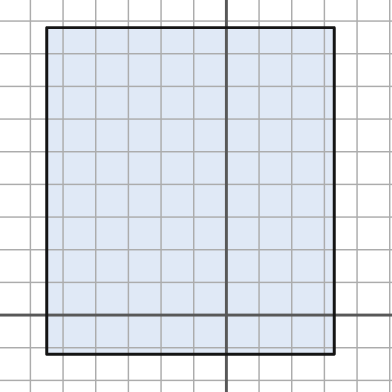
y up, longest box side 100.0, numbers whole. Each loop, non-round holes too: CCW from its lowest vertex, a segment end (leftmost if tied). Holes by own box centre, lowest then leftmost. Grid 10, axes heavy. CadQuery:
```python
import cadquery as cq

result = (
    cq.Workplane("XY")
    .moveTo(-55.0, -12.0)
    .lineTo(33.0, -12.0)
    .lineTo(33.0, 88.0)
    .lineTo(-55.0, 88.0)
    .close()
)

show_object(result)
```